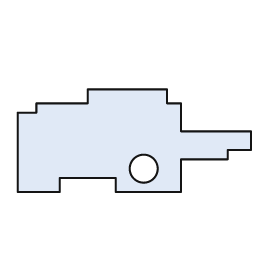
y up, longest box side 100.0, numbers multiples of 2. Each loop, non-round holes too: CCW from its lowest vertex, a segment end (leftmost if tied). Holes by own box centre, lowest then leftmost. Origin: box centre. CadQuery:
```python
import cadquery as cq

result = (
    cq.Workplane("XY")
    .moveTo(-50.0, -22.0)
    .lineTo(-32.0, -22.0)
    .lineTo(-32.0, -16.0)
    .lineTo(-8.0, -16.0)
    .lineTo(-8.0, -22.0)
    .lineTo(20.0, -22.0)
    .lineTo(20.0, -8.0)
    .lineTo(40.0, -8.0)
    .lineTo(40.0, -4.0)
    .lineTo(50.0, -4.0)
    .lineTo(50.0, 4.0)
    .lineTo(20.0, 4.0)
    .lineTo(20.0, 16.0)
    .lineTo(14.0, 16.0)
    .lineTo(14.0, 22.0)
    .lineTo(-20.0, 22.0)
    .lineTo(-20.0, 16.0)
    .lineTo(-42.0, 16.0)
    .lineTo(-42.0, 12.0)
    .lineTo(-50.0, 12.0)
    .close()
    .moveTo(4.0, -12.0)
    .circle(6.0)
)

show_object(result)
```